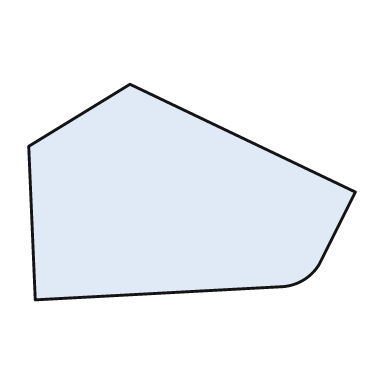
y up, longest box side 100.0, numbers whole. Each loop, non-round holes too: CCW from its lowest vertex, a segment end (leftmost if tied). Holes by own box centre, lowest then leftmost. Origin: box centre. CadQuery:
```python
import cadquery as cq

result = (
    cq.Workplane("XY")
    .moveTo(-48.0, -33.0)
    .lineTo(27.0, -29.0)
    .threePointArc((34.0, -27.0), (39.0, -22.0))
    .lineTo(50.0, 0.0)
    .lineTo(-19.0, 33.0)
    .lineTo(-50.0, 14.0)
    .close()
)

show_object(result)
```